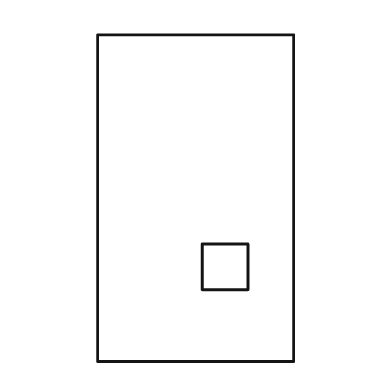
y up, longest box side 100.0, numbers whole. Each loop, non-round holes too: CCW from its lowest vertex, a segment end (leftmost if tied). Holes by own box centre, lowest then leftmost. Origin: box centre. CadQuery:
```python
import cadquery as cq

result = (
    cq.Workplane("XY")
    .moveTo(-30.0, -50.0)
    .lineTo(30.0, -50.0)
    .lineTo(30.0, 50.0)
    .lineTo(-30.0, 50.0)
    .close()
    .moveTo(2.0, -28.0)
    .lineTo(16.0, -28.0)
    .lineTo(16.0, -14.0)
    .lineTo(2.0, -14.0)
    .close()
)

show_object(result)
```